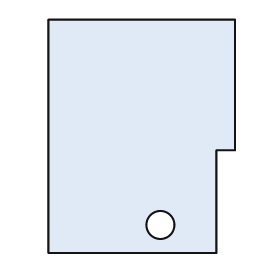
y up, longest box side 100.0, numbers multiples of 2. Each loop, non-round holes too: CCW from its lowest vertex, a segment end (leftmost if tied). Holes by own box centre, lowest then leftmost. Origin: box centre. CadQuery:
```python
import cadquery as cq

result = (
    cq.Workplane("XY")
    .moveTo(-40.0, -50.0)
    .lineTo(32.0, -50.0)
    .lineTo(32.0, -6.0)
    .lineTo(40.0, -6.0)
    .lineTo(40.0, 50.0)
    .lineTo(-40.0, 50.0)
    .close()
    .moveTo(8.0, -38.0)
    .circle(6.0)
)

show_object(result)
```